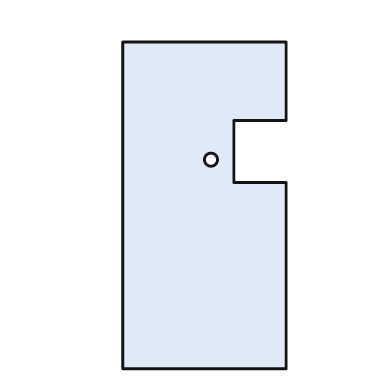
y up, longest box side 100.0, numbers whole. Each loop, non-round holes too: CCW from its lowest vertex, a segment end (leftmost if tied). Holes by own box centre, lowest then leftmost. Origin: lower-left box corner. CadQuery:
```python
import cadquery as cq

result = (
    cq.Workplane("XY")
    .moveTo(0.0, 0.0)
    .lineTo(50.0, 0.0)
    .lineTo(50.0, 57.0)
    .lineTo(34.0, 57.0)
    .lineTo(34.0, 76.0)
    .lineTo(50.0, 76.0)
    .lineTo(50.0, 100.0)
    .lineTo(0.0, 100.0)
    .close()
    .moveTo(27.0, 64.0)
    .circle(2.0)
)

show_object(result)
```